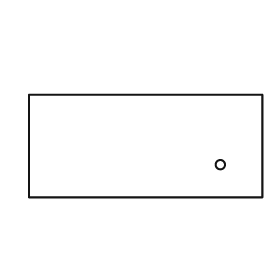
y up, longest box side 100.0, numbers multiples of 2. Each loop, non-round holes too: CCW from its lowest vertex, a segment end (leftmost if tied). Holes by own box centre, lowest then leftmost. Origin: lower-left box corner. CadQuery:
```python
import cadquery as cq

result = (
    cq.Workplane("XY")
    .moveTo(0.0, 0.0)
    .lineTo(100.0, 0.0)
    .lineTo(100.0, 44.0)
    .lineTo(0.0, 44.0)
    .close()
    .moveTo(82.0, 14.0)
    .circle(2.0)
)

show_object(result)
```